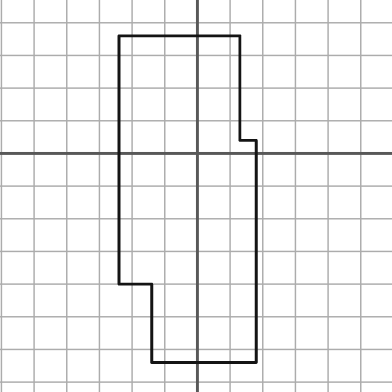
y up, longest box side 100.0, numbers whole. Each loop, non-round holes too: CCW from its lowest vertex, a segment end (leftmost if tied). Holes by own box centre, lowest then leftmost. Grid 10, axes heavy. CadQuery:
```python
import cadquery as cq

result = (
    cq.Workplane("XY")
    .moveTo(-14.0, -64.0)
    .lineTo(18.0, -64.0)
    .lineTo(18.0, 4.0)
    .lineTo(13.0, 4.0)
    .lineTo(13.0, 36.0)
    .lineTo(-24.0, 36.0)
    .lineTo(-24.0, -40.0)
    .lineTo(-14.0, -40.0)
    .close()
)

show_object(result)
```